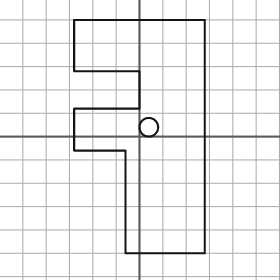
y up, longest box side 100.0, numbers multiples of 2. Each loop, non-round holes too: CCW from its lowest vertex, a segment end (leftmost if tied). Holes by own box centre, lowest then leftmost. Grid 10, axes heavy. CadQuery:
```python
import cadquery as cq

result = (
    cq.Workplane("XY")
    .moveTo(-6.0, -50.0)
    .lineTo(28.0, -50.0)
    .lineTo(28.0, 50.0)
    .lineTo(-28.0, 50.0)
    .lineTo(-28.0, 28.0)
    .lineTo(0.0, 28.0)
    .lineTo(0.0, 12.0)
    .lineTo(-28.0, 12.0)
    .lineTo(-28.0, -6.0)
    .lineTo(-6.0, -6.0)
    .close()
    .moveTo(4.0, 4.0)
    .circle(4.0)
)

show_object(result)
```